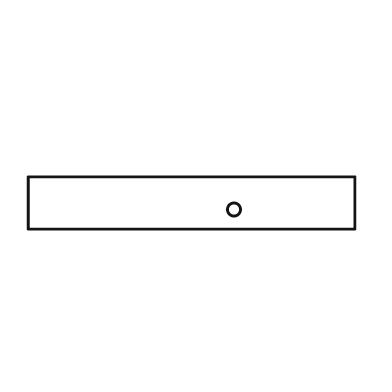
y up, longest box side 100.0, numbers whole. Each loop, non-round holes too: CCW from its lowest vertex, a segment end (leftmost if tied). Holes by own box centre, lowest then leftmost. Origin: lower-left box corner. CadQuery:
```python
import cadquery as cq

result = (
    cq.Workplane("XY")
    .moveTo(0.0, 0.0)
    .lineTo(100.0, 0.0)
    .lineTo(100.0, 16.0)
    .lineTo(0.0, 16.0)
    .close()
    .moveTo(63.0, 6.0)
    .circle(2.0)
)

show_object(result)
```